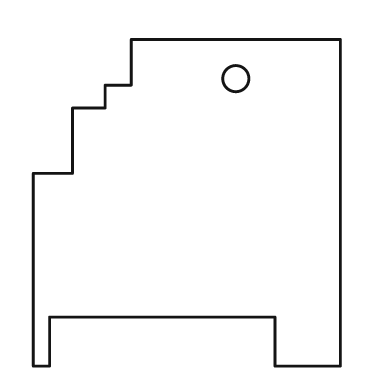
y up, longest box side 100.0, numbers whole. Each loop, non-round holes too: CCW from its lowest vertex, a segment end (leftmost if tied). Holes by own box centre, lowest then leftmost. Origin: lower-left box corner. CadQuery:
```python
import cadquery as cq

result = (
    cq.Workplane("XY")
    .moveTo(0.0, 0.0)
    .lineTo(5.0, 0.0)
    .lineTo(5.0, 15.0)
    .lineTo(74.0, 15.0)
    .lineTo(74.0, 0.0)
    .lineTo(94.0, 0.0)
    .lineTo(94.0, 100.0)
    .lineTo(30.0, 100.0)
    .lineTo(30.0, 86.0)
    .lineTo(22.0, 86.0)
    .lineTo(22.0, 79.0)
    .lineTo(12.0, 79.0)
    .lineTo(12.0, 59.0)
    .lineTo(0.0, 59.0)
    .close()
    .moveTo(62.0, 88.0)
    .circle(4.0)
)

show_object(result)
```